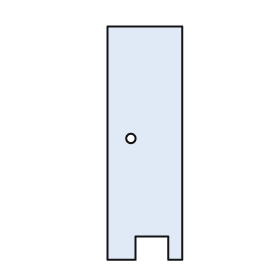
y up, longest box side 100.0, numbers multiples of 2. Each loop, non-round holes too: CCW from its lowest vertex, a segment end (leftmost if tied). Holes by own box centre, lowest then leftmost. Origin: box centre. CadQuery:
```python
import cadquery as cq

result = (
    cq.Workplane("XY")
    .moveTo(-16.0, -50.0)
    .lineTo(-4.0, -50.0)
    .lineTo(-4.0, -40.0)
    .lineTo(10.0, -40.0)
    .lineTo(10.0, -50.0)
    .lineTo(16.0, -50.0)
    .lineTo(16.0, 50.0)
    .lineTo(-16.0, 50.0)
    .close()
    .moveTo(-6.0, 2.0)
    .circle(2.0)
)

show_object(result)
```